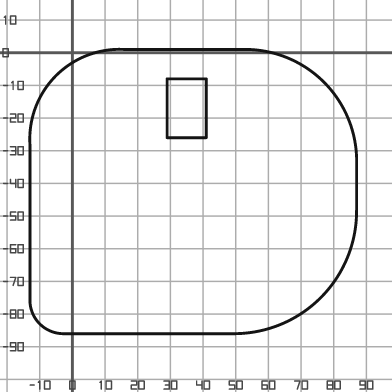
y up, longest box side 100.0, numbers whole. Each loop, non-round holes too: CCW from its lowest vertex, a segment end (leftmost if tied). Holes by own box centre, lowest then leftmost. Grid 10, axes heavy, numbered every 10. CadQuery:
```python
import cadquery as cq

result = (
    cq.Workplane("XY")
    .moveTo(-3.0, -86.0)
    .lineTo(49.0, -86.0)
    .threePointArc((76.0, -75.0), (87.0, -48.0))
    .lineTo(87.0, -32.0)
    .threePointArc((77.0, -9.0), (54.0, 1.0))
    .lineTo(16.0, 1.0)
    .threePointArc((-5.0, -7.0), (-13.0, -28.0))
    .lineTo(-13.0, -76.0)
    .threePointArc((-10.0, -83.0), (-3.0, -86.0))
    .close()
    .moveTo(29.0, -26.0)
    .lineTo(41.0, -26.0)
    .lineTo(41.0, -8.0)
    .lineTo(29.0, -8.0)
    .close()
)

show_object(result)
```